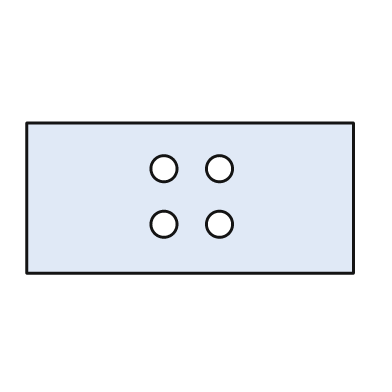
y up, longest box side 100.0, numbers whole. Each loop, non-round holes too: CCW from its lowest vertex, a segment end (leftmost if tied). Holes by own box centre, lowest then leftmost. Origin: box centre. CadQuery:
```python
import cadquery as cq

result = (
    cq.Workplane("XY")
    .moveTo(-50.0, -23.0)
    .lineTo(50.0, -23.0)
    .lineTo(50.0, 23.0)
    .lineTo(-50.0, 23.0)
    .close()
    .moveTo(-8.0, -8.0)
    .circle(4.0)
    .moveTo(9.0, -8.0)
    .circle(4.0)
    .moveTo(-8.0, 9.0)
    .circle(4.0)
    .moveTo(9.0, 9.0)
    .circle(4.0)
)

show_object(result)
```